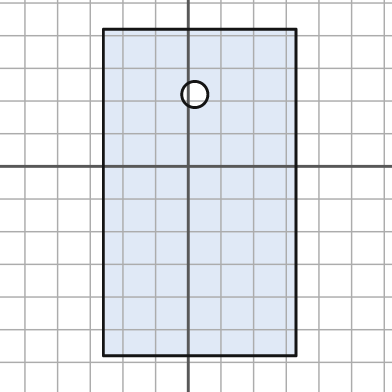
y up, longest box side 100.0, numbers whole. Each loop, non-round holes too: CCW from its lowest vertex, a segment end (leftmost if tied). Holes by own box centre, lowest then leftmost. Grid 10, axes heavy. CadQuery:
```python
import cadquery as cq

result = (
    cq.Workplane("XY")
    .moveTo(-26.0, -58.0)
    .lineTo(33.0, -58.0)
    .lineTo(33.0, 42.0)
    .lineTo(-26.0, 42.0)
    .close()
    .moveTo(2.0, 22.0)
    .circle(4.0)
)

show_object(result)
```